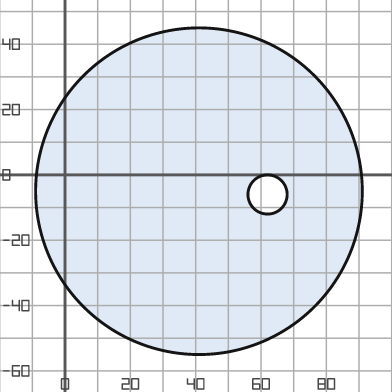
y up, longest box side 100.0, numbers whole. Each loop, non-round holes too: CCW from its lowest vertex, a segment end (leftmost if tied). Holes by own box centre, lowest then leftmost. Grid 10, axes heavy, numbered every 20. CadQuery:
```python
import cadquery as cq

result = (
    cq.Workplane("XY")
    .moveTo(41.0, -5.0)
    .circle(50.0)
    .moveTo(62.0, -6.0)
    .circle(6.0)
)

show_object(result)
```